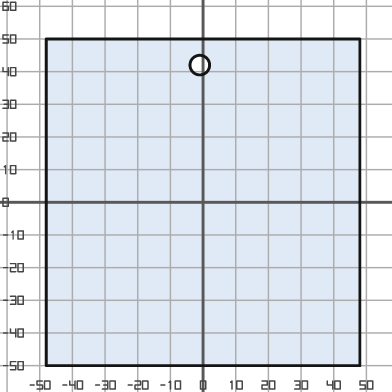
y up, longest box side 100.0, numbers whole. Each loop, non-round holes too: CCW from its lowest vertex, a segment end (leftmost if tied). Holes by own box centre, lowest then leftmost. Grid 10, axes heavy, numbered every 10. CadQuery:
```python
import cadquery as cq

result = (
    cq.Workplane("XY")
    .moveTo(-48.0, -50.0)
    .lineTo(48.0, -50.0)
    .lineTo(48.0, 50.0)
    .lineTo(-48.0, 50.0)
    .close()
    .moveTo(-1.0, 42.0)
    .circle(3.0)
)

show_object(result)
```